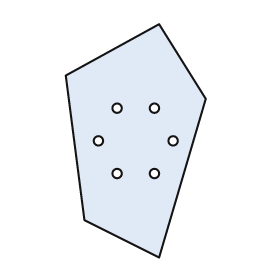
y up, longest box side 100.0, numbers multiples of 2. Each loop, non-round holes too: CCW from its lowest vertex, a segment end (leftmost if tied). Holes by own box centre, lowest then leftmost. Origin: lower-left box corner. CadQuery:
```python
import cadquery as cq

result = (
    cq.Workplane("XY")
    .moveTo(40.0, 0.0)
    .lineTo(60.0, 68.0)
    .lineTo(40.0, 100.0)
    .lineTo(0.0, 78.0)
    .lineTo(8.0, 16.0)
    .close()
    .moveTo(22.0, 36.0)
    .circle(2.0)
    .moveTo(38.0, 36.0)
    .circle(2.0)
    .moveTo(14.0, 50.0)
    .circle(2.0)
    .moveTo(46.0, 50.0)
    .circle(2.0)
    .moveTo(22.0, 64.0)
    .circle(2.0)
    .moveTo(38.0, 64.0)
    .circle(2.0)
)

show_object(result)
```